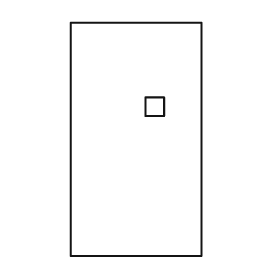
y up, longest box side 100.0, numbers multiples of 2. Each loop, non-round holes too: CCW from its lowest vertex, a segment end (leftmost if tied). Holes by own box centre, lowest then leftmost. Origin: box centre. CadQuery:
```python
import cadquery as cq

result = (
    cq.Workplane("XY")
    .moveTo(-28.0, -50.0)
    .lineTo(28.0, -50.0)
    .lineTo(28.0, 50.0)
    .lineTo(-28.0, 50.0)
    .close()
    .moveTo(4.0, 10.0)
    .lineTo(12.0, 10.0)
    .lineTo(12.0, 18.0)
    .lineTo(4.0, 18.0)
    .close()
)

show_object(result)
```